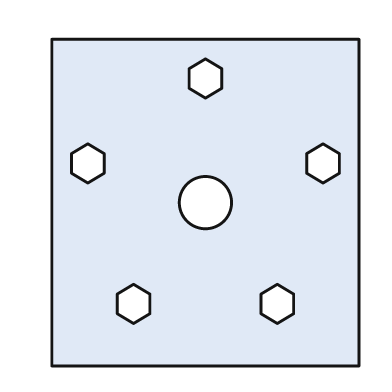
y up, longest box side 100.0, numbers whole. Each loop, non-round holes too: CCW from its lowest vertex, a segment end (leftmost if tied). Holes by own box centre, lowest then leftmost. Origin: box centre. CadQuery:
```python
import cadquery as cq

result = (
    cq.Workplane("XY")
    .moveTo(-47.0, -50.0)
    .lineTo(47.0, -50.0)
    .lineTo(47.0, 50.0)
    .lineTo(-47.0, 50.0)
    .close()
    .moveTo(-22.0, -37.0)
    .lineTo(-17.0, -34.0)
    .lineTo(-17.0, -28.0)
    .lineTo(-22.0, -25.0)
    .lineTo(-27.0, -28.0)
    .lineTo(-27.0, -34.0)
    .close()
    .moveTo(22.0, -37.0)
    .lineTo(27.0, -34.0)
    .lineTo(27.0, -28.0)
    .lineTo(22.0, -25.0)
    .lineTo(17.0, -28.0)
    .lineTo(17.0, -34.0)
    .close()
    .moveTo(0.0, 0.0)
    .circle(8.0)
    .moveTo(-36.0, 6.0)
    .lineTo(-31.0, 9.0)
    .lineTo(-31.0, 15.0)
    .lineTo(-36.0, 18.0)
    .lineTo(-41.0, 15.0)
    .lineTo(-41.0, 9.0)
    .close()
    .moveTo(36.0, 6.0)
    .lineTo(41.0, 9.0)
    .lineTo(41.0, 15.0)
    .lineTo(36.0, 18.0)
    .lineTo(31.0, 15.0)
    .lineTo(31.0, 9.0)
    .close()
    .moveTo(0.0, 32.0)
    .lineTo(5.0, 35.0)
    .lineTo(5.0, 41.0)
    .lineTo(0.0, 44.0)
    .lineTo(-5.0, 41.0)
    .lineTo(-5.0, 35.0)
    .close()
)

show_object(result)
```